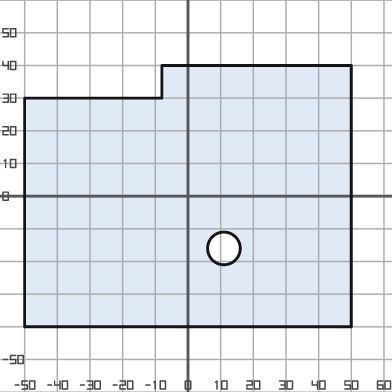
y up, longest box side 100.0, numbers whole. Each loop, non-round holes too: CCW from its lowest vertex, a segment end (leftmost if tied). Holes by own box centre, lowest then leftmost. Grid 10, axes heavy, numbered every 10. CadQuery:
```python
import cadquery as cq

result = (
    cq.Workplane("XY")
    .moveTo(-50.0, -40.0)
    .lineTo(50.0, -40.0)
    .lineTo(50.0, 40.0)
    .lineTo(-8.0, 40.0)
    .lineTo(-8.0, 30.0)
    .lineTo(-50.0, 30.0)
    .close()
    .moveTo(11.0, -16.0)
    .circle(5.0)
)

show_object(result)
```